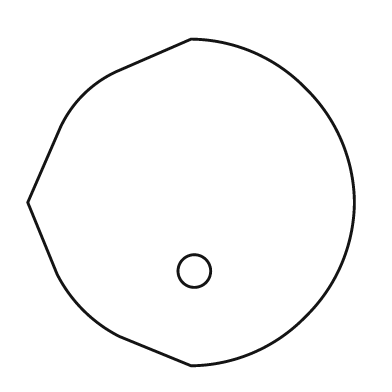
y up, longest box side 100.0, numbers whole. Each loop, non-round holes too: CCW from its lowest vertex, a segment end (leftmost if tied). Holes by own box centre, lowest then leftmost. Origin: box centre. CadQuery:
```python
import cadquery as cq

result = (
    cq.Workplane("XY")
    .moveTo(0.0, -50.0)
    .threePointArc((19.0, -46.0), (35.0, -35.0))
    .threePointArc((46.0, -19.0), (50.0, 0.0))
    .threePointArc((46.0, 19.0), (35.0, 35.0))
    .threePointArc((19.0, 46.0), (0.0, 50.0))
    .lineTo(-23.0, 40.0)
    .threePointArc((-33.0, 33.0), (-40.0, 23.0))
    .lineTo(-50.0, 0.0)
    .lineTo(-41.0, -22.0)
    .threePointArc((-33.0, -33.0), (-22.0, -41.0))
    .close()
    .moveTo(1.0, -21.0)
    .circle(5.0)
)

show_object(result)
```